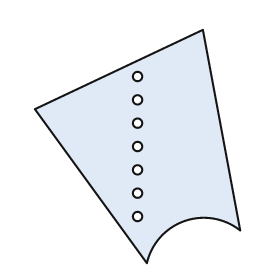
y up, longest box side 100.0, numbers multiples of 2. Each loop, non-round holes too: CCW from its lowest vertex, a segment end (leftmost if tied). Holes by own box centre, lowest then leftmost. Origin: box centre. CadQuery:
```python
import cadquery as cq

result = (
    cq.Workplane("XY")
    .moveTo(4.0, -50.0)
    .threePointArc((20.0, -32.0), (44.0, -36.0))
    .lineTo(28.0, 50.0)
    .lineTo(-44.0, 16.0)
    .close()
    .moveTo(0.0, -30.0)
    .circle(2.0)
    .moveTo(0.0, -20.0)
    .circle(2.0)
    .moveTo(0.0, -10.0)
    .circle(2.0)
    .moveTo(0.0, 0.0)
    .circle(2.0)
    .moveTo(0.0, 10.0)
    .circle(2.0)
    .moveTo(0.0, 20.0)
    .circle(2.0)
    .moveTo(0.0, 30.0)
    .circle(2.0)
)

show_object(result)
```